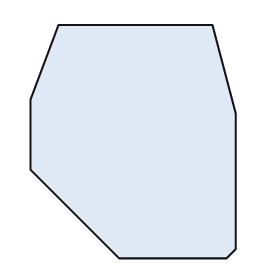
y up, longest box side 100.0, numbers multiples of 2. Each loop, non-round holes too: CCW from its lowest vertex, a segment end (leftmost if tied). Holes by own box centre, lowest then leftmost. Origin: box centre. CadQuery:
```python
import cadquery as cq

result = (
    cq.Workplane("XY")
    .moveTo(-6.0, -50.0)
    .lineTo(40.0, -50.0)
    .lineTo(44.0, -46.0)
    .lineTo(44.0, 12.0)
    .lineTo(34.0, 50.0)
    .lineTo(-32.0, 50.0)
    .lineTo(-44.0, 18.0)
    .lineTo(-44.0, -12.0)
    .close()
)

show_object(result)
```